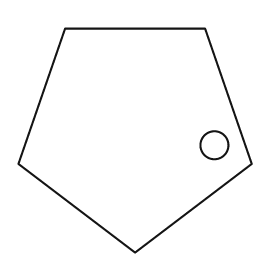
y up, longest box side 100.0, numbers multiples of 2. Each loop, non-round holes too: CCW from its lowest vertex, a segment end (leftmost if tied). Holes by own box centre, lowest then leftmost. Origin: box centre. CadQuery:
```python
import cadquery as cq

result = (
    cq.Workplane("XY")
    .moveTo(0.0, -48.0)
    .lineTo(50.0, -10.0)
    .lineTo(30.0, 48.0)
    .lineTo(-30.0, 48.0)
    .lineTo(-50.0, -10.0)
    .close()
    .moveTo(34.0, -2.0)
    .circle(6.0)
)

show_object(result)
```